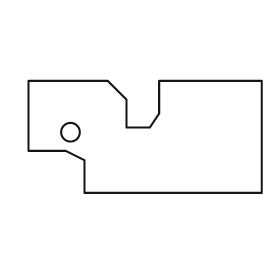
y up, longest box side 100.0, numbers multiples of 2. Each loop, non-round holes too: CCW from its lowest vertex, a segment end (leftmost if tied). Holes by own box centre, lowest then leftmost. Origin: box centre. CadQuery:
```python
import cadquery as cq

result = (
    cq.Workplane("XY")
    .moveTo(-26.0, -24.0)
    .lineTo(50.0, -24.0)
    .lineTo(50.0, 24.0)
    .lineTo(6.0, 24.0)
    .lineTo(6.0, 10.0)
    .lineTo(2.0, 4.0)
    .lineTo(-8.0, 4.0)
    .lineTo(-8.0, 16.0)
    .lineTo(-16.0, 24.0)
    .lineTo(-50.0, 24.0)
    .lineTo(-50.0, -6.0)
    .lineTo(-34.0, -6.0)
    .lineTo(-26.0, -10.0)
    .close()
    .moveTo(-32.0, 2.0)
    .circle(4.0)
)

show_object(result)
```